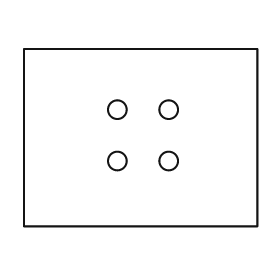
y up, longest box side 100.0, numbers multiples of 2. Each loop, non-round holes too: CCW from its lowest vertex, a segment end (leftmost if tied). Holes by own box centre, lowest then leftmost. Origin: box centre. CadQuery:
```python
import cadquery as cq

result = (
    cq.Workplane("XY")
    .moveTo(-50.0, -38.0)
    .lineTo(50.0, -38.0)
    .lineTo(50.0, 38.0)
    .lineTo(-50.0, 38.0)
    .close()
    .moveTo(-10.0, -10.0)
    .circle(4.0)
    .moveTo(12.0, -10.0)
    .circle(4.0)
    .moveTo(-10.0, 12.0)
    .circle(4.0)
    .moveTo(12.0, 12.0)
    .circle(4.0)
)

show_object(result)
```